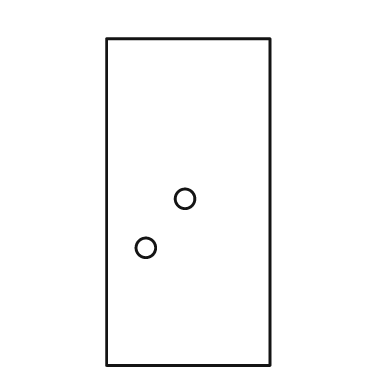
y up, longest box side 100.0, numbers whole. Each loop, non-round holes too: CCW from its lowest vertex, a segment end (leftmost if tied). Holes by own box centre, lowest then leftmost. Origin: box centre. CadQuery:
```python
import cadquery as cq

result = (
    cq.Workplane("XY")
    .moveTo(-25.0, -50.0)
    .lineTo(25.0, -50.0)
    .lineTo(25.0, 50.0)
    .lineTo(-25.0, 50.0)
    .close()
    .moveTo(-13.0, -14.0)
    .circle(3.0)
    .moveTo(-1.0, 1.0)
    .circle(3.0)
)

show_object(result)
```